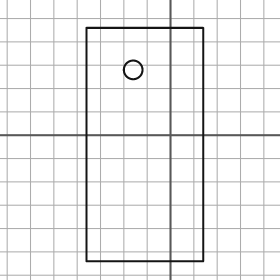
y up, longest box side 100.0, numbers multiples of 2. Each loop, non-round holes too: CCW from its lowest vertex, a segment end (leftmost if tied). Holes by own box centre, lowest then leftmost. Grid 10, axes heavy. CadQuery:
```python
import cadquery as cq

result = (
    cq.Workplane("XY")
    .moveTo(-36.0, -54.0)
    .lineTo(14.0, -54.0)
    .lineTo(14.0, 46.0)
    .lineTo(-36.0, 46.0)
    .close()
    .moveTo(-16.0, 28.0)
    .circle(4.0)
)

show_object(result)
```